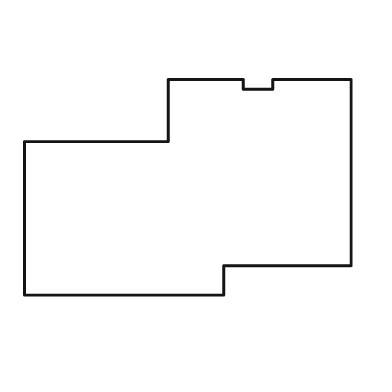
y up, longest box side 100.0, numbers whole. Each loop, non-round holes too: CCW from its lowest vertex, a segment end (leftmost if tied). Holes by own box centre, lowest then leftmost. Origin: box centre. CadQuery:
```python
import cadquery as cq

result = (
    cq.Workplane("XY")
    .moveTo(-50.0, -33.0)
    .lineTo(11.0, -33.0)
    .lineTo(11.0, -24.0)
    .lineTo(50.0, -24.0)
    .lineTo(50.0, 33.0)
    .lineTo(26.0, 33.0)
    .lineTo(26.0, 30.0)
    .lineTo(17.0, 30.0)
    .lineTo(17.0, 33.0)
    .lineTo(-6.0, 33.0)
    .lineTo(-6.0, 14.0)
    .lineTo(-50.0, 14.0)
    .close()
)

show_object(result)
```